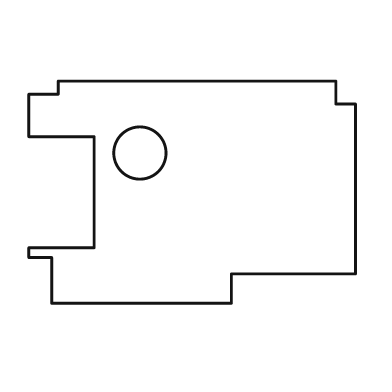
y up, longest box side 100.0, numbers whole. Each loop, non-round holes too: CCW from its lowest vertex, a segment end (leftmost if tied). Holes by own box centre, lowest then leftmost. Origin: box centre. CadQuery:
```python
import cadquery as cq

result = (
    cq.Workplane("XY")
    .moveTo(-43.0, -34.0)
    .lineTo(12.0, -34.0)
    .lineTo(12.0, -25.0)
    .lineTo(50.0, -25.0)
    .lineTo(50.0, 27.0)
    .lineTo(44.0, 27.0)
    .lineTo(44.0, 34.0)
    .lineTo(-41.0, 34.0)
    .lineTo(-41.0, 30.0)
    .lineTo(-50.0, 30.0)
    .lineTo(-50.0, 17.0)
    .lineTo(-30.0, 17.0)
    .lineTo(-30.0, -17.0)
    .lineTo(-50.0, -17.0)
    .lineTo(-50.0, -20.0)
    .lineTo(-43.0, -20.0)
    .close()
    .moveTo(-16.0, 12.0)
    .circle(8.0)
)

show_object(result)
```